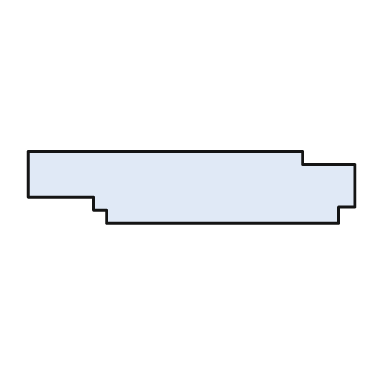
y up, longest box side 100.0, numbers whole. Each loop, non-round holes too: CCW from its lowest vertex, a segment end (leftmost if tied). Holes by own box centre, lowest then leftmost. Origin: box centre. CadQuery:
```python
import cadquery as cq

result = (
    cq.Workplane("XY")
    .moveTo(-26.0, -11.0)
    .lineTo(45.0, -11.0)
    .lineTo(45.0, -6.0)
    .lineTo(50.0, -6.0)
    .lineTo(50.0, 7.0)
    .lineTo(34.0, 7.0)
    .lineTo(34.0, 11.0)
    .lineTo(-50.0, 11.0)
    .lineTo(-50.0, -3.0)
    .lineTo(-30.0, -3.0)
    .lineTo(-30.0, -7.0)
    .lineTo(-26.0, -7.0)
    .close()
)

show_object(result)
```